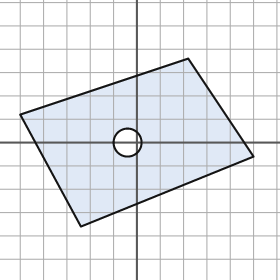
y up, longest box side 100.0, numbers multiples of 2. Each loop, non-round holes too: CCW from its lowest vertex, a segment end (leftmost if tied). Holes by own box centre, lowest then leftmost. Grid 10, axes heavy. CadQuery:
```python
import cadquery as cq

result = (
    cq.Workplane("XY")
    .moveTo(-24.0, -36.0)
    .lineTo(50.0, -6.0)
    .lineTo(22.0, 36.0)
    .lineTo(-50.0, 12.0)
    .close()
    .moveTo(-4.0, 0.0)
    .circle(6.0)
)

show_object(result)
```